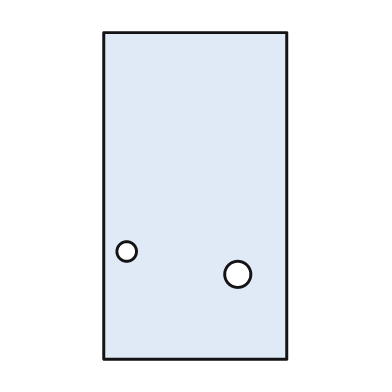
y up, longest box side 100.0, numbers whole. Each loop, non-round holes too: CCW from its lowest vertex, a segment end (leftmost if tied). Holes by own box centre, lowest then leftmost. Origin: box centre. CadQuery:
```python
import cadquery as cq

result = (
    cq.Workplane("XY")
    .moveTo(-28.0, -50.0)
    .lineTo(28.0, -50.0)
    .lineTo(28.0, 50.0)
    .lineTo(-28.0, 50.0)
    .close()
    .moveTo(13.0, -24.0)
    .circle(4.0)
    .moveTo(-21.0, -17.0)
    .circle(3.0)
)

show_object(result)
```